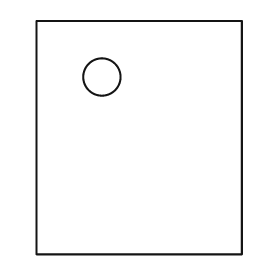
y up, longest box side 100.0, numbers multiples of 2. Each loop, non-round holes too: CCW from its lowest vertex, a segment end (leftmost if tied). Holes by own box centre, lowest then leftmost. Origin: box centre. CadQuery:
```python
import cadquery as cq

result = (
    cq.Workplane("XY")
    .moveTo(-44.0, -50.0)
    .lineTo(44.0, -50.0)
    .lineTo(44.0, 50.0)
    .lineTo(-44.0, 50.0)
    .close()
    .moveTo(-16.0, 26.0)
    .circle(8.0)
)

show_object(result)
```